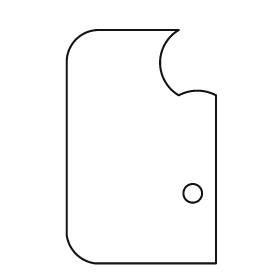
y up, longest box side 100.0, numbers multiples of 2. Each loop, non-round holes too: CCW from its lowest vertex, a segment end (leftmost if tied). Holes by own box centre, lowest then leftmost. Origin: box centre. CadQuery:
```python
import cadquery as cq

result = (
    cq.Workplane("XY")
    .moveTo(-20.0, -50.0)
    .lineTo(32.0, -50.0)
    .lineTo(32.0, 22.0)
    .threePointArc((24.0, 24.0), (16.0, 22.0))
    .threePointArc((8.0, 36.0), (16.0, 50.0))
    .lineTo(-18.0, 50.0)
    .threePointArc((-28.0, 46.0), (-32.0, 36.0))
    .lineTo(-32.0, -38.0)
    .threePointArc((-28.0, -46.0), (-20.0, -50.0))
    .close()
    .moveTo(22.0, -20.0)
    .circle(4.0)
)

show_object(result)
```